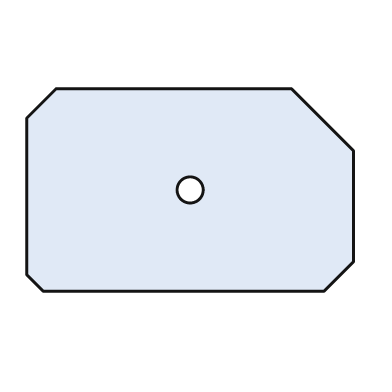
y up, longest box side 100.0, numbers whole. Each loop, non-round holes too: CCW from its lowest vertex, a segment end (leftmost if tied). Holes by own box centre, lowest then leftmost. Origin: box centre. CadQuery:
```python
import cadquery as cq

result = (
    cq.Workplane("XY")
    .moveTo(-45.0, -31.0)
    .lineTo(41.0, -31.0)
    .lineTo(50.0, -22.0)
    .lineTo(50.0, 12.0)
    .lineTo(31.0, 31.0)
    .lineTo(-41.0, 31.0)
    .lineTo(-50.0, 22.0)
    .lineTo(-50.0, -26.0)
    .close()
    .moveTo(0.0, 0.0)
    .circle(4.0)
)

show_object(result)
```